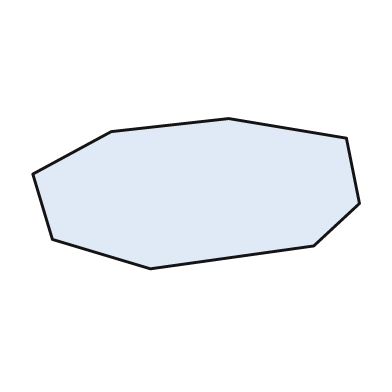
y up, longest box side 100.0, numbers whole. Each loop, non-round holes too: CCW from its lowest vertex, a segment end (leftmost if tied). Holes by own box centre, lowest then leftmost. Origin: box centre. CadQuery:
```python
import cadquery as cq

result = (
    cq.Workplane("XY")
    .moveTo(-14.0, -23.0)
    .lineTo(36.0, -16.0)
    .lineTo(50.0, -3.0)
    .lineTo(46.0, 17.0)
    .lineTo(10.0, 23.0)
    .lineTo(-26.0, 19.0)
    .lineTo(-50.0, 6.0)
    .lineTo(-44.0, -14.0)
    .close()
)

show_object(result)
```